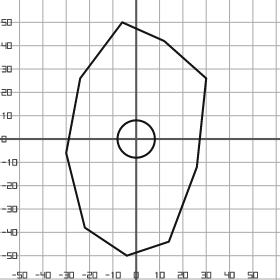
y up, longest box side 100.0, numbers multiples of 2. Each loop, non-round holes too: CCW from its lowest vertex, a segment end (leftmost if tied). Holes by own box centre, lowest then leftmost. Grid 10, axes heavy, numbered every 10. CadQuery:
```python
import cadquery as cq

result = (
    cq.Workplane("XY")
    .moveTo(-4.0, -50.0)
    .lineTo(14.0, -44.0)
    .lineTo(26.0, -12.0)
    .lineTo(30.0, 26.0)
    .lineTo(12.0, 42.0)
    .lineTo(-6.0, 50.0)
    .lineTo(-24.0, 26.0)
    .lineTo(-30.0, -6.0)
    .lineTo(-22.0, -38.0)
    .close()
    .moveTo(0.0, 0.0)
    .circle(8.0)
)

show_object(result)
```